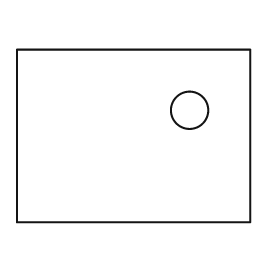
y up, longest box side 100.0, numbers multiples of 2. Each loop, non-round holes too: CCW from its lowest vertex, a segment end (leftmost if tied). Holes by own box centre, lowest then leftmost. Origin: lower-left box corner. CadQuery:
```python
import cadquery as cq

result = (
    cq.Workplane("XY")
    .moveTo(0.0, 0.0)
    .lineTo(100.0, 0.0)
    .lineTo(100.0, 74.0)
    .lineTo(0.0, 74.0)
    .close()
    .moveTo(74.0, 48.0)
    .circle(8.0)
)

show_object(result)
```